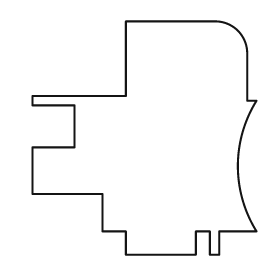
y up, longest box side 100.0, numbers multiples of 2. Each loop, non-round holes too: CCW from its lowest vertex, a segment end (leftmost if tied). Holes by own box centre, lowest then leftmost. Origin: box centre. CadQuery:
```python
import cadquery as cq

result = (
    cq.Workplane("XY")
    .moveTo(-8.0, -50.0)
    .lineTo(22.0, -50.0)
    .lineTo(22.0, -40.0)
    .lineTo(28.0, -40.0)
    .lineTo(28.0, -50.0)
    .lineTo(32.0, -50.0)
    .lineTo(32.0, -40.0)
    .lineTo(48.0, -40.0)
    .threePointArc((40.0, -12.0), (48.0, 16.0))
    .lineTo(44.0, 16.0)
    .lineTo(44.0, 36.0)
    .threePointArc((40.0, 46.0), (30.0, 50.0))
    .lineTo(-8.0, 50.0)
    .lineTo(-8.0, 18.0)
    .lineTo(-48.0, 18.0)
    .lineTo(-48.0, 14.0)
    .lineTo(-30.0, 14.0)
    .lineTo(-30.0, -4.0)
    .lineTo(-48.0, -4.0)
    .lineTo(-48.0, -24.0)
    .lineTo(-18.0, -24.0)
    .lineTo(-18.0, -40.0)
    .lineTo(-8.0, -40.0)
    .close()
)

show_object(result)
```